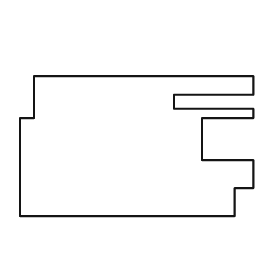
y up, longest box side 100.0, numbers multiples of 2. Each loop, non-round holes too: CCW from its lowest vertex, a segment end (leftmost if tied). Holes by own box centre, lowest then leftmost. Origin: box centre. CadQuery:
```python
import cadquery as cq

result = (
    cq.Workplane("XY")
    .moveTo(-50.0, -30.0)
    .lineTo(42.0, -30.0)
    .lineTo(42.0, -18.0)
    .lineTo(50.0, -18.0)
    .lineTo(50.0, -6.0)
    .lineTo(28.0, -6.0)
    .lineTo(28.0, 12.0)
    .lineTo(50.0, 12.0)
    .lineTo(50.0, 16.0)
    .lineTo(16.0, 16.0)
    .lineTo(16.0, 22.0)
    .lineTo(50.0, 22.0)
    .lineTo(50.0, 30.0)
    .lineTo(-44.0, 30.0)
    .lineTo(-44.0, 12.0)
    .lineTo(-50.0, 12.0)
    .close()
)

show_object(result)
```